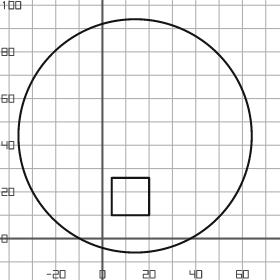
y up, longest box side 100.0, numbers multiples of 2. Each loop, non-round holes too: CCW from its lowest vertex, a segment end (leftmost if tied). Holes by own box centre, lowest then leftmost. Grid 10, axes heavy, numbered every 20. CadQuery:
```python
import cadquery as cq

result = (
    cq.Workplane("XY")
    .moveTo(14.0, 44.0)
    .circle(50.0)
    .moveTo(4.0, 10.0)
    .lineTo(20.0, 10.0)
    .lineTo(20.0, 26.0)
    .lineTo(4.0, 26.0)
    .close()
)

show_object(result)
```